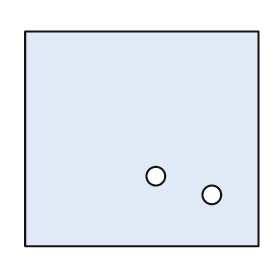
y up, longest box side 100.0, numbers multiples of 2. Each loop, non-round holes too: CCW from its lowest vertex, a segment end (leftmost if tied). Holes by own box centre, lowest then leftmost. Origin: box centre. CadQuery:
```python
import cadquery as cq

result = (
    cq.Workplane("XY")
    .moveTo(-50.0, -46.0)
    .lineTo(50.0, -46.0)
    .lineTo(50.0, 46.0)
    .lineTo(-50.0, 46.0)
    .close()
    .moveTo(30.0, -24.0)
    .circle(4.0)
    .moveTo(6.0, -16.0)
    .circle(4.0)
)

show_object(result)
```